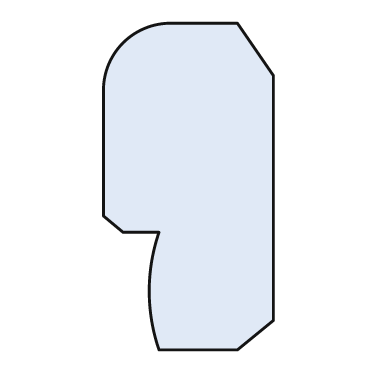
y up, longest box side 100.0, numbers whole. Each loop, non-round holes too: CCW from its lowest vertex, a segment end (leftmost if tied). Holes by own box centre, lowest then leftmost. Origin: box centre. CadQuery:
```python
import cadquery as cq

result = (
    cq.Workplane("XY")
    .moveTo(-9.0, -50.0)
    .lineTo(15.0, -50.0)
    .lineTo(26.0, -41.0)
    .lineTo(26.0, 34.0)
    .lineTo(15.0, 50.0)
    .lineTo(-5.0, 50.0)
    .threePointArc((-20.0, 44.0), (-26.0, 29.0))
    .lineTo(-26.0, -9.0)
    .lineTo(-20.0, -14.0)
    .lineTo(-9.0, -14.0)
    .threePointArc((-12.0, -32.0), (-9.0, -50.0))
    .close()
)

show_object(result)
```